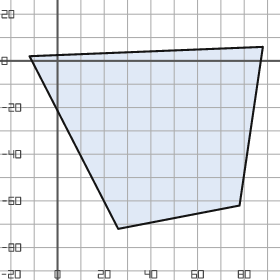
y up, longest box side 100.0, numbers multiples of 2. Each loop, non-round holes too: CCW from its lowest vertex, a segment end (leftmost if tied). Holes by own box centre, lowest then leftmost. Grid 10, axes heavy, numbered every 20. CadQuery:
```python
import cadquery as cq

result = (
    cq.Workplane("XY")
    .moveTo(26.0, -72.0)
    .lineTo(78.0, -62.0)
    .lineTo(88.0, 6.0)
    .lineTo(-12.0, 2.0)
    .close()
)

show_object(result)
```